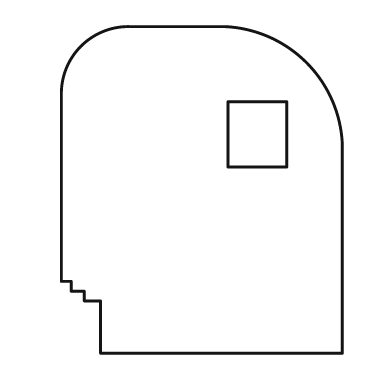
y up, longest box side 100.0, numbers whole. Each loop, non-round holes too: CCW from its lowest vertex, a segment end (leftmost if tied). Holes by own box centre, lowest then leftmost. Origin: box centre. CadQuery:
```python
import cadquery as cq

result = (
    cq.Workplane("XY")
    .moveTo(-31.0, -50.0)
    .lineTo(43.0, -50.0)
    .lineTo(43.0, 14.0)
    .threePointArc((32.0, 39.0), (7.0, 50.0))
    .lineTo(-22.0, 50.0)
    .threePointArc((-37.0, 44.0), (-43.0, 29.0))
    .lineTo(-43.0, -28.0)
    .lineTo(-40.0, -28.0)
    .lineTo(-40.0, -31.0)
    .lineTo(-36.0, -31.0)
    .lineTo(-36.0, -34.0)
    .lineTo(-31.0, -34.0)
    .close()
    .moveTo(8.0, 7.0)
    .lineTo(26.0, 7.0)
    .lineTo(26.0, 27.0)
    .lineTo(8.0, 27.0)
    .close()
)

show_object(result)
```